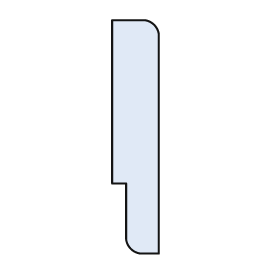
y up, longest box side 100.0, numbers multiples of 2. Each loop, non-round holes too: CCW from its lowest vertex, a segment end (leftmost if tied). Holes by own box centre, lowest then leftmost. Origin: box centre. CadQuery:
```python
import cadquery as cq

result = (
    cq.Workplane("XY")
    .moveTo(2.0, -50.0)
    .lineTo(10.0, -50.0)
    .lineTo(10.0, 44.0)
    .threePointArc((8.0, 48.0), (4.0, 50.0))
    .lineTo(-10.0, 50.0)
    .lineTo(-10.0, -20.0)
    .lineTo(-4.0, -20.0)
    .lineTo(-4.0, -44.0)
    .threePointArc((-2.0, -48.0), (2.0, -50.0))
    .close()
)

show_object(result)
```